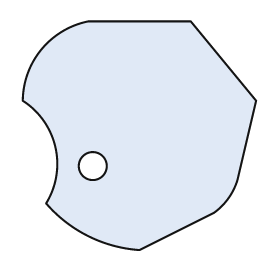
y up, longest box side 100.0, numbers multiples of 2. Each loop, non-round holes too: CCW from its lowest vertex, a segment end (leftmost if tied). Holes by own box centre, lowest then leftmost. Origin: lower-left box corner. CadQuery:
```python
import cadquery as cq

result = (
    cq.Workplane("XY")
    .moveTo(50.0, 0.0)
    .lineTo(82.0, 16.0)
    .threePointArc((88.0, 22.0), (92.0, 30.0))
    .lineTo(100.0, 64.0)
    .lineTo(72.0, 98.0)
    .lineTo(28.0, 98.0)
    .threePointArc((8.0, 86.0), (0.0, 64.0))
    .threePointArc((14.0, 44.0), (10.0, 20.0))
    .threePointArc((28.0, 6.0), (50.0, 0.0))
    .close()
    .moveTo(30.0, 36.0)
    .circle(6.0)
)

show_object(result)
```